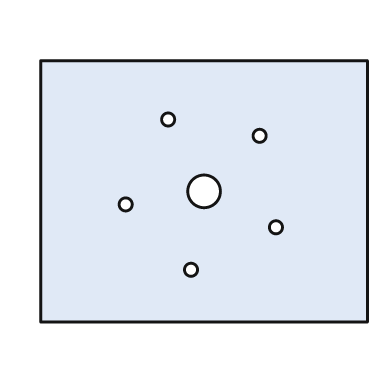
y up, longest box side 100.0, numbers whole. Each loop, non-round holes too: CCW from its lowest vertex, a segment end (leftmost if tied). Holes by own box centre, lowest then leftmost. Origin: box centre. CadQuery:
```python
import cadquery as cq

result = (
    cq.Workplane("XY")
    .moveTo(-50.0, -40.0)
    .lineTo(50.0, -40.0)
    .lineTo(50.0, 40.0)
    .lineTo(-50.0, 40.0)
    .close()
    .moveTo(-4.0, -24.0)
    .circle(2.0)
    .moveTo(22.0, -11.0)
    .circle(2.0)
    .moveTo(-24.0, -4.0)
    .circle(2.0)
    .moveTo(0.0, 0.0)
    .circle(5.0)
    .moveTo(17.0, 17.0)
    .circle(2.0)
    .moveTo(-11.0, 22.0)
    .circle(2.0)
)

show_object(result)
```